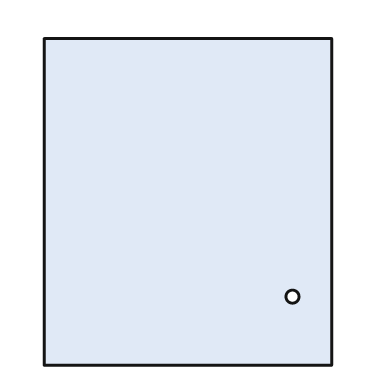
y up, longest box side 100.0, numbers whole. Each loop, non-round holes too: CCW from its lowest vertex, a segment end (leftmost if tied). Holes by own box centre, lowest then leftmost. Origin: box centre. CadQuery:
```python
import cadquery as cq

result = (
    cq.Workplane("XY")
    .moveTo(-44.0, -50.0)
    .lineTo(44.0, -50.0)
    .lineTo(44.0, 50.0)
    .lineTo(-44.0, 50.0)
    .close()
    .moveTo(32.0, -29.0)
    .circle(2.0)
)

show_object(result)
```